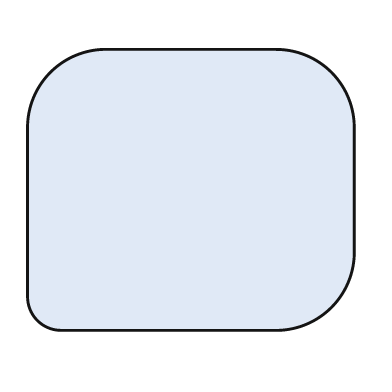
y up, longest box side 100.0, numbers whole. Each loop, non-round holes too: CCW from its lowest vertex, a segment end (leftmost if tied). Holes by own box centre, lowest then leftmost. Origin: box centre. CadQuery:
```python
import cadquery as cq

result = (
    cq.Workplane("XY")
    .moveTo(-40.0, -43.0)
    .lineTo(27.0, -43.0)
    .threePointArc((43.0, -36.0), (50.0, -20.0))
    .lineTo(50.0, 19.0)
    .threePointArc((43.0, 36.0), (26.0, 43.0))
    .lineTo(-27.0, 43.0)
    .threePointArc((-43.0, 36.0), (-50.0, 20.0))
    .lineTo(-50.0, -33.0)
    .threePointArc((-47.0, -40.0), (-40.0, -43.0))
    .close()
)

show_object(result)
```